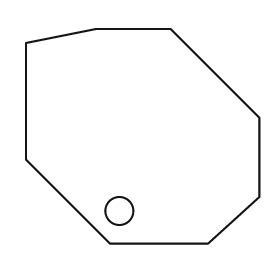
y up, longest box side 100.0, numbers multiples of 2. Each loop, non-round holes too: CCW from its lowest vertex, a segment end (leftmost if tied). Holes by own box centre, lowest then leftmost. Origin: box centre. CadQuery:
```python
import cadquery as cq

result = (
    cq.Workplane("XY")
    .moveTo(-14.0, -46.0)
    .lineTo(28.0, -46.0)
    .lineTo(50.0, -26.0)
    .lineTo(50.0, 8.0)
    .lineTo(12.0, 46.0)
    .lineTo(-20.0, 46.0)
    .lineTo(-50.0, 40.0)
    .lineTo(-50.0, -10.0)
    .close()
    .moveTo(-10.0, -32.0)
    .circle(6.0)
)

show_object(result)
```